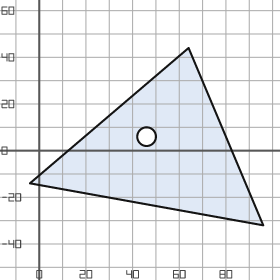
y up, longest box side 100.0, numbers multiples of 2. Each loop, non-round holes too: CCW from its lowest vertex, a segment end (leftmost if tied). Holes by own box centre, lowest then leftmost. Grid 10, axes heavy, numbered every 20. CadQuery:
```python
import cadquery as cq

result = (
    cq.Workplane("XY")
    .moveTo(96.0, -32.0)
    .lineTo(64.0, 44.0)
    .lineTo(-4.0, -14.0)
    .close()
    .moveTo(46.0, 6.0)
    .circle(4.0)
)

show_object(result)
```